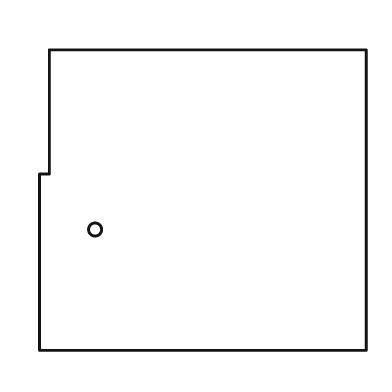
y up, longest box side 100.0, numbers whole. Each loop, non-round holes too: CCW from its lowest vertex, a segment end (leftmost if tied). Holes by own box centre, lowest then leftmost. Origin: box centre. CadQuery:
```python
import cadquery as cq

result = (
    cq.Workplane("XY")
    .moveTo(-50.0, -46.0)
    .lineTo(50.0, -46.0)
    .lineTo(50.0, 46.0)
    .lineTo(-47.0, 46.0)
    .lineTo(-47.0, 8.0)
    .lineTo(-50.0, 8.0)
    .close()
    .moveTo(-33.0, -9.0)
    .circle(2.0)
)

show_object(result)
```